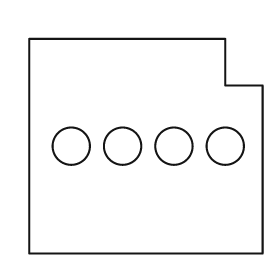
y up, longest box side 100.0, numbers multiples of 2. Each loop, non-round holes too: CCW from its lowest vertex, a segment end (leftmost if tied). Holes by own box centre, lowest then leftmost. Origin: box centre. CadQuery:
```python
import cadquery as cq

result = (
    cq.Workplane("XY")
    .moveTo(-50.0, -46.0)
    .lineTo(50.0, -46.0)
    .lineTo(50.0, 26.0)
    .lineTo(34.0, 26.0)
    .lineTo(34.0, 46.0)
    .lineTo(-50.0, 46.0)
    .close()
    .moveTo(-32.0, 0.0)
    .circle(8.0)
    .moveTo(-10.0, 0.0)
    .circle(8.0)
    .moveTo(12.0, 0.0)
    .circle(8.0)
    .moveTo(34.0, 0.0)
    .circle(8.0)
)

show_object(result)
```